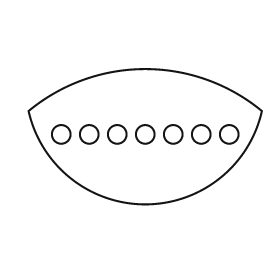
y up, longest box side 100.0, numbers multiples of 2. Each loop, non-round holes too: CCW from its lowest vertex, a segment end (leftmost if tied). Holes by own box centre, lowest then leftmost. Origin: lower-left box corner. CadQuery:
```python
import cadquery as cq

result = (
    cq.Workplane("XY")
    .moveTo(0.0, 40.0)
    .threePointArc((50.0, 0.0), (100.0, 40.0))
    .threePointArc((50.0, 58.0), (0.0, 40.0))
    .close()
    .moveTo(14.0, 30.0)
    .circle(4.0)
    .moveTo(26.0, 30.0)
    .circle(4.0)
    .moveTo(38.0, 30.0)
    .circle(4.0)
    .moveTo(50.0, 30.0)
    .circle(4.0)
    .moveTo(62.0, 30.0)
    .circle(4.0)
    .moveTo(74.0, 30.0)
    .circle(4.0)
    .moveTo(86.0, 30.0)
    .circle(4.0)
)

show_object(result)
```